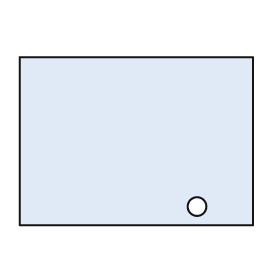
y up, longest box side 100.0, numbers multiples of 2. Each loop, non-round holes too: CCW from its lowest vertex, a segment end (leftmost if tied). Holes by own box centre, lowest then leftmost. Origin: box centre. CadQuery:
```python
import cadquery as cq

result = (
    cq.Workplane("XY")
    .moveTo(-50.0, -36.0)
    .lineTo(50.0, -36.0)
    .lineTo(50.0, 36.0)
    .lineTo(-50.0, 36.0)
    .close()
    .moveTo(26.0, -28.0)
    .circle(4.0)
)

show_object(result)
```